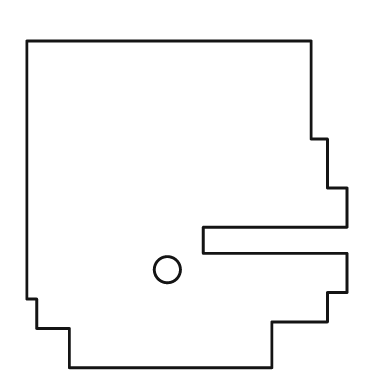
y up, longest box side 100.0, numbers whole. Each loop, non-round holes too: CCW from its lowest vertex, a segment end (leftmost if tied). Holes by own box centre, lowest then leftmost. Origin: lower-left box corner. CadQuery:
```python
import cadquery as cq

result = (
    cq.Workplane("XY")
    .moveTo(13.0, 0.0)
    .lineTo(75.0, 0.0)
    .lineTo(75.0, 14.0)
    .lineTo(92.0, 14.0)
    .lineTo(92.0, 23.0)
    .lineTo(98.0, 23.0)
    .lineTo(98.0, 35.0)
    .lineTo(54.0, 35.0)
    .lineTo(54.0, 43.0)
    .lineTo(98.0, 43.0)
    .lineTo(98.0, 55.0)
    .lineTo(92.0, 55.0)
    .lineTo(92.0, 70.0)
    .lineTo(87.0, 70.0)
    .lineTo(87.0, 100.0)
    .lineTo(0.0, 100.0)
    .lineTo(0.0, 21.0)
    .lineTo(3.0, 21.0)
    .lineTo(3.0, 12.0)
    .lineTo(13.0, 12.0)
    .close()
    .moveTo(43.0, 30.0)
    .circle(4.0)
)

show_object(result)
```